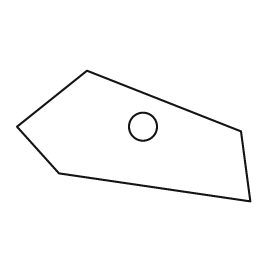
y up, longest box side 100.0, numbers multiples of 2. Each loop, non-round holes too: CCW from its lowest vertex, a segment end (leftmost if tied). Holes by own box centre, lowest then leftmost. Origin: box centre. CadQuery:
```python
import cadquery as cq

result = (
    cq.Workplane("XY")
    .moveTo(50.0, -28.0)
    .lineTo(46.0, 2.0)
    .lineTo(-20.0, 28.0)
    .lineTo(-50.0, 4.0)
    .lineTo(-32.0, -16.0)
    .close()
    .moveTo(4.0, 4.0)
    .circle(6.0)
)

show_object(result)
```